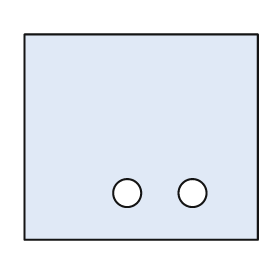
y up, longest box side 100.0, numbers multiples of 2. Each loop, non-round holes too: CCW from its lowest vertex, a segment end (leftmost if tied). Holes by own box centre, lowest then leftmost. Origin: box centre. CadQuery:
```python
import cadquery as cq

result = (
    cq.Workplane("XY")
    .moveTo(-50.0, -44.0)
    .lineTo(50.0, -44.0)
    .lineTo(50.0, 44.0)
    .lineTo(-50.0, 44.0)
    .close()
    .moveTo(-6.0, -24.0)
    .circle(6.0)
    .moveTo(22.0, -24.0)
    .circle(6.0)
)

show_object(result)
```